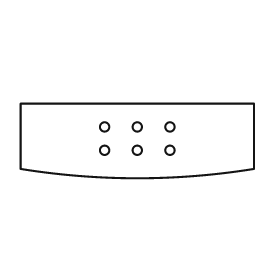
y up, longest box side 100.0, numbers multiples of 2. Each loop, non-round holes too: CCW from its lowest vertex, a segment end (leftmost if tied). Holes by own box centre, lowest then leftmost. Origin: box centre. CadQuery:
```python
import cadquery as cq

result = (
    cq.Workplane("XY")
    .moveTo(-50.0, -12.0)
    .threePointArc((0.0, -16.0), (50.0, -12.0))
    .lineTo(50.0, 16.0)
    .lineTo(-50.0, 16.0)
    .close()
    .moveTo(-14.0, -4.0)
    .circle(2.0)
    .moveTo(0.0, -4.0)
    .circle(2.0)
    .moveTo(14.0, -4.0)
    .circle(2.0)
    .moveTo(-14.0, 6.0)
    .circle(2.0)
    .moveTo(0.0, 6.0)
    .circle(2.0)
    .moveTo(14.0, 6.0)
    .circle(2.0)
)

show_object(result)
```